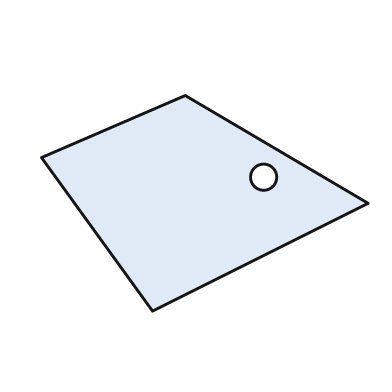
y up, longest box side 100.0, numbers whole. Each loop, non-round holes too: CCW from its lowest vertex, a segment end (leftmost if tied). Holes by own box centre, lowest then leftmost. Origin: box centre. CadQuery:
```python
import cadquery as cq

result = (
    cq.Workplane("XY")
    .moveTo(-16.0, -33.0)
    .lineTo(50.0, 0.0)
    .lineTo(-6.0, 33.0)
    .lineTo(-50.0, 14.0)
    .close()
    .moveTo(18.0, 8.0)
    .circle(4.0)
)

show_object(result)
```